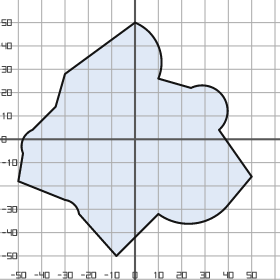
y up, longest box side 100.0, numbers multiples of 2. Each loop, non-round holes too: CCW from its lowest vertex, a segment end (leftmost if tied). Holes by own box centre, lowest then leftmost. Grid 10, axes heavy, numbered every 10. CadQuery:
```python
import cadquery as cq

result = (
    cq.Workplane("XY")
    .moveTo(-8.0, -50.0)
    .lineTo(10.0, -32.0)
    .threePointArc((26.0, -36.0), (40.0, -28.0))
    .lineTo(50.0, -16.0)
    .lineTo(36.0, 4.0)
    .threePointArc((38.0, 18.0), (24.0, 22.0))
    .lineTo(10.0, 26.0)
    .threePointArc((10.0, 40.0), (0.0, 50.0))
    .lineTo(-30.0, 28.0)
    .lineTo(-34.0, 14.0)
    .lineTo(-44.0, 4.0)
    .threePointArc((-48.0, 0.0), (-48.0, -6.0))
    .lineTo(-50.0, -18.0)
    .lineTo(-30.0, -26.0)
    .threePointArc((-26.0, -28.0), (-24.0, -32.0))
    .close()
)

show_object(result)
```